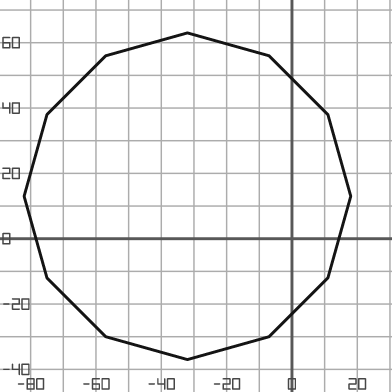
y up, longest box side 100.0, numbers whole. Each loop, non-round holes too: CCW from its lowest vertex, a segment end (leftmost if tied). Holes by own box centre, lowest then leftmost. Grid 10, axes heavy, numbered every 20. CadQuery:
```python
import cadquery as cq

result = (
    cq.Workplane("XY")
    .moveTo(-32.0, -37.0)
    .lineTo(-7.0, -30.0)
    .lineTo(11.0, -12.0)
    .lineTo(18.0, 13.0)
    .lineTo(11.0, 38.0)
    .lineTo(-7.0, 56.0)
    .lineTo(-32.0, 63.0)
    .lineTo(-57.0, 56.0)
    .lineTo(-75.0, 38.0)
    .lineTo(-82.0, 13.0)
    .lineTo(-75.0, -12.0)
    .lineTo(-57.0, -30.0)
    .close()
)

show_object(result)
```